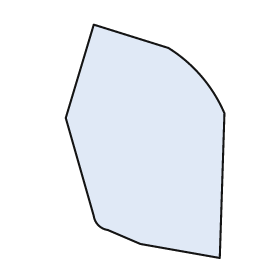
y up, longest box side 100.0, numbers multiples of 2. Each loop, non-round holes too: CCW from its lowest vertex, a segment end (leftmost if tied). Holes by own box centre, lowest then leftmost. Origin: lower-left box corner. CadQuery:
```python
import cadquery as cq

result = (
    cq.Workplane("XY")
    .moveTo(66.0, 0.0)
    .lineTo(68.0, 62.0)
    .threePointArc((58.0, 78.0), (44.0, 90.0))
    .lineTo(12.0, 100.0)
    .lineTo(0.0, 60.0)
    .lineTo(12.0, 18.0)
    .threePointArc((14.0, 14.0), (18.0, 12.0))
    .lineTo(32.0, 6.0)
    .close()
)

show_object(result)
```